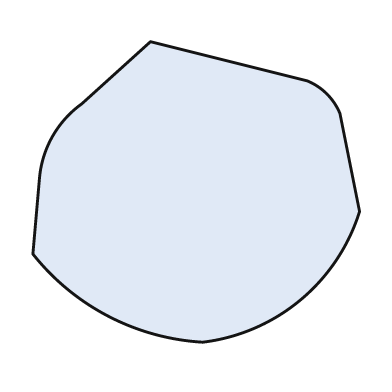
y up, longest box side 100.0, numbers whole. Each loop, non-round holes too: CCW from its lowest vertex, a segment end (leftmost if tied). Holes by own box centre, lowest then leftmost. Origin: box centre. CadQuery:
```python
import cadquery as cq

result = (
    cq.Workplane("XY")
    .moveTo(2.0, -46.0)
    .threePointArc((32.0, -33.0), (50.0, -6.0))
    .lineTo(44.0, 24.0)
    .threePointArc((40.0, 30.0), (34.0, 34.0))
    .lineTo(-14.0, 46.0)
    .lineTo(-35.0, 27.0)
    .threePointArc((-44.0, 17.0), (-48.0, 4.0))
    .lineTo(-50.0, -19.0)
    .threePointArc((-27.0, -38.0), (2.0, -46.0))
    .close()
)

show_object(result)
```